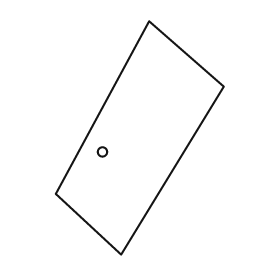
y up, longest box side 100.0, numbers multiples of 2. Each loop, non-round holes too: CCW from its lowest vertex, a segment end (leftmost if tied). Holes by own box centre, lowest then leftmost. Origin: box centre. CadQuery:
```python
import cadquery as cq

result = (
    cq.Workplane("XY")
    .moveTo(-8.0, -50.0)
    .lineTo(36.0, 22.0)
    .lineTo(4.0, 50.0)
    .lineTo(-36.0, -24.0)
    .close()
    .moveTo(-16.0, -6.0)
    .circle(2.0)
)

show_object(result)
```